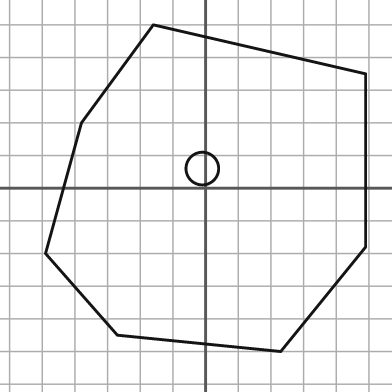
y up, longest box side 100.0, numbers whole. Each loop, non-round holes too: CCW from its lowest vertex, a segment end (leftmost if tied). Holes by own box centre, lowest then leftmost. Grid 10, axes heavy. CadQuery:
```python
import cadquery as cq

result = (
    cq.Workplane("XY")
    .moveTo(23.0, -50.0)
    .lineTo(49.0, -18.0)
    .lineTo(49.0, 35.0)
    .lineTo(-16.0, 50.0)
    .lineTo(-38.0, 20.0)
    .lineTo(-49.0, -20.0)
    .lineTo(-27.0, -45.0)
    .close()
    .moveTo(-1.0, 6.0)
    .circle(5.0)
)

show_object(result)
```